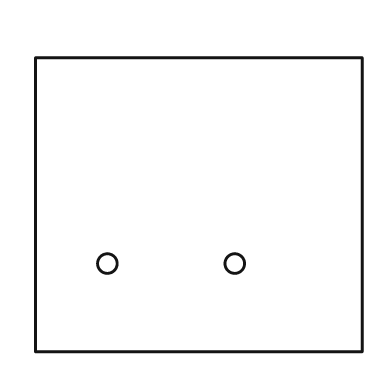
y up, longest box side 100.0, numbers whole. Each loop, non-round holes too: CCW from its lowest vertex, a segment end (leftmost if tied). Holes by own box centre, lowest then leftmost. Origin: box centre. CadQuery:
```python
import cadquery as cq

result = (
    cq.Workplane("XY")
    .moveTo(-50.0, -45.0)
    .lineTo(50.0, -45.0)
    .lineTo(50.0, 45.0)
    .lineTo(-50.0, 45.0)
    .close()
    .moveTo(-28.0, -18.0)
    .circle(3.0)
    .moveTo(11.0, -18.0)
    .circle(3.0)
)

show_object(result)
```